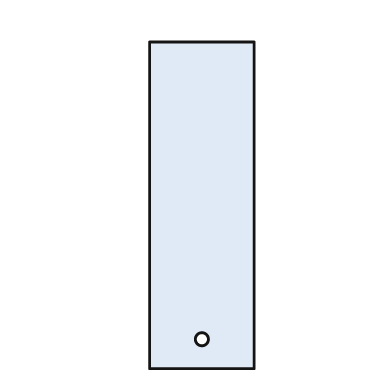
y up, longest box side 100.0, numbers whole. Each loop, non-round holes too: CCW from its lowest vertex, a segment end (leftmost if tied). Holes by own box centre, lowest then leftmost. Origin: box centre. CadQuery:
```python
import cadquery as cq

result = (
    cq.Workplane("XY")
    .moveTo(-16.0, -50.0)
    .lineTo(16.0, -50.0)
    .lineTo(16.0, 50.0)
    .lineTo(-16.0, 50.0)
    .close()
    .moveTo(0.0, -41.0)
    .circle(2.0)
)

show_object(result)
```